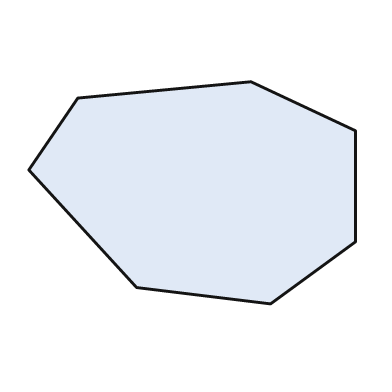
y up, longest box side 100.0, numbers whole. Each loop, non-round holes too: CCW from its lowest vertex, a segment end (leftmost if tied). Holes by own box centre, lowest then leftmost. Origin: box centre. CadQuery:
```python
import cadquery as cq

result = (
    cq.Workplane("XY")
    .moveTo(24.0, -34.0)
    .lineTo(50.0, -15.0)
    .lineTo(50.0, 19.0)
    .lineTo(18.0, 34.0)
    .lineTo(-35.0, 29.0)
    .lineTo(-50.0, 7.0)
    .lineTo(-17.0, -29.0)
    .close()
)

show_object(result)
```